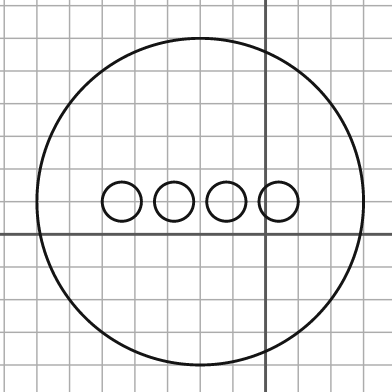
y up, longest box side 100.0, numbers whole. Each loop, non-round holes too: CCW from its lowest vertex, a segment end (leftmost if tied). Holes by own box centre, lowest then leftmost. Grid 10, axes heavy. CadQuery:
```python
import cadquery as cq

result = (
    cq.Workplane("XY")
    .moveTo(-20.0, 10.0)
    .circle(50.0)
    .moveTo(-44.0, 10.0)
    .circle(6.0)
    .moveTo(-28.0, 10.0)
    .circle(6.0)
    .moveTo(-12.0, 10.0)
    .circle(6.0)
    .moveTo(4.0, 10.0)
    .circle(6.0)
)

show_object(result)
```